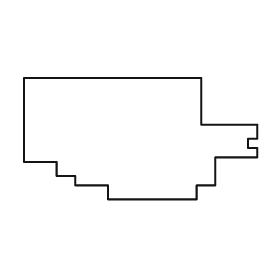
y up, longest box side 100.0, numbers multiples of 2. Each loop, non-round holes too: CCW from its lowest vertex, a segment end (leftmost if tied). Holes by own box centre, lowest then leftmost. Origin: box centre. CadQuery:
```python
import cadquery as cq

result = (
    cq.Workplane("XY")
    .moveTo(-14.0, -26.0)
    .lineTo(24.0, -26.0)
    .lineTo(24.0, -20.0)
    .lineTo(32.0, -20.0)
    .lineTo(32.0, -8.0)
    .lineTo(50.0, -8.0)
    .lineTo(50.0, -4.0)
    .lineTo(46.0, -4.0)
    .lineTo(46.0, 0.0)
    .lineTo(50.0, 0.0)
    .lineTo(50.0, 6.0)
    .lineTo(26.0, 6.0)
    .lineTo(26.0, 26.0)
    .lineTo(-50.0, 26.0)
    .lineTo(-50.0, -10.0)
    .lineTo(-36.0, -10.0)
    .lineTo(-36.0, -16.0)
    .lineTo(-28.0, -16.0)
    .lineTo(-28.0, -20.0)
    .lineTo(-14.0, -20.0)
    .close()
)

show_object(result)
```